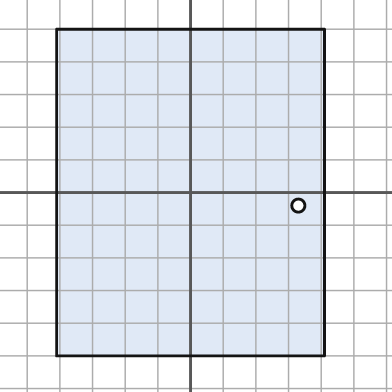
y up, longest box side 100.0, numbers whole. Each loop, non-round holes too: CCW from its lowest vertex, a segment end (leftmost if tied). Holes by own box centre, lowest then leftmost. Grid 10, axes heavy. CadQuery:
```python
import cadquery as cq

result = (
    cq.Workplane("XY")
    .moveTo(-41.0, -50.0)
    .lineTo(41.0, -50.0)
    .lineTo(41.0, 50.0)
    .lineTo(-41.0, 50.0)
    .close()
    .moveTo(33.0, -4.0)
    .circle(2.0)
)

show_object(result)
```